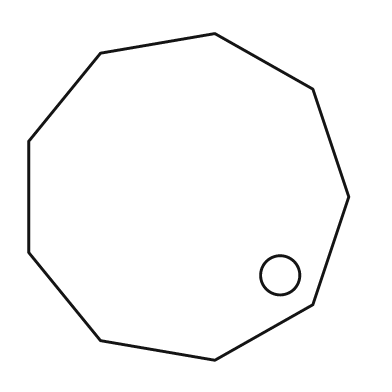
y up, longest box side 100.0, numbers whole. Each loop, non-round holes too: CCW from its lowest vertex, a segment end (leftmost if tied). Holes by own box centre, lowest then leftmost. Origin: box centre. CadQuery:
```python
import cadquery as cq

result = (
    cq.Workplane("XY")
    .moveTo(8.0, -50.0)
    .lineTo(38.0, -33.0)
    .lineTo(49.0, 0.0)
    .lineTo(38.0, 33.0)
    .lineTo(8.0, 50.0)
    .lineTo(-27.0, 44.0)
    .lineTo(-49.0, 17.0)
    .lineTo(-49.0, -17.0)
    .lineTo(-27.0, -44.0)
    .close()
    .moveTo(28.0, -24.0)
    .circle(6.0)
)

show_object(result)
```